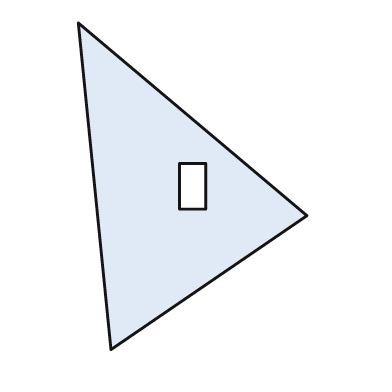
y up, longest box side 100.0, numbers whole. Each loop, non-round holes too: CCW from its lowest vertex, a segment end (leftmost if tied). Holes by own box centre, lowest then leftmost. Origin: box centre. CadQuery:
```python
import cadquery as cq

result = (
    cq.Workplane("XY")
    .moveTo(-25.0, -50.0)
    .lineTo(35.0, -9.0)
    .lineTo(-35.0, 50.0)
    .close()
    .moveTo(-4.0, -7.0)
    .lineTo(4.0, -7.0)
    .lineTo(4.0, 7.0)
    .lineTo(-4.0, 7.0)
    .close()
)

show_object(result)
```